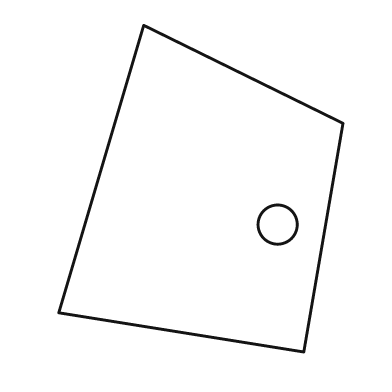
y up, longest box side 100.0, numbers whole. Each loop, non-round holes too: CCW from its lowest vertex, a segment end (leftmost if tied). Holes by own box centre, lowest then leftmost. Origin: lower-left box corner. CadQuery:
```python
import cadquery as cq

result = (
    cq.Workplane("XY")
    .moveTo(75.0, 0.0)
    .lineTo(87.0, 70.0)
    .lineTo(26.0, 100.0)
    .lineTo(0.0, 12.0)
    .close()
    .moveTo(67.0, 39.0)
    .circle(6.0)
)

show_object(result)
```